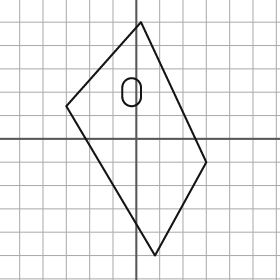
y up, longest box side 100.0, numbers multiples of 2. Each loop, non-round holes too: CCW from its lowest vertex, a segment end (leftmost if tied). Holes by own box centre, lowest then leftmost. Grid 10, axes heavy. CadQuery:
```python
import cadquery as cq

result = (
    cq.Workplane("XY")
    .moveTo(8.0, -50.0)
    .lineTo(30.0, -10.0)
    .lineTo(2.0, 50.0)
    .lineTo(-30.0, 14.0)
    .close()
    .moveTo(-6.0, 18.0)
    .threePointArc((-2.0, 14.0), (2.0, 18.0))
    .lineTo(2.0, 22.0)
    .threePointArc((-2.0, 26.0), (-6.0, 22.0))
    .close()
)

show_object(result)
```